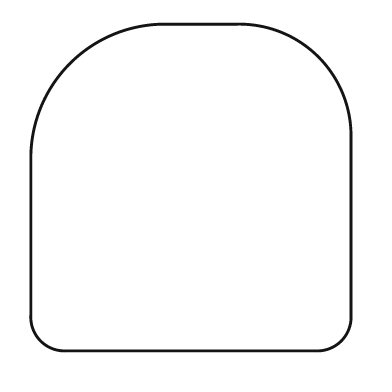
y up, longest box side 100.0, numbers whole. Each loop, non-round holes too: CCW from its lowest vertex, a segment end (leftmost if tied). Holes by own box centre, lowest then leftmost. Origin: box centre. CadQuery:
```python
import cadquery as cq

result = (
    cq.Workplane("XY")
    .moveTo(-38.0, -50.0)
    .lineTo(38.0, -50.0)
    .threePointArc((46.0, -47.0), (49.0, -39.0))
    .lineTo(49.0, 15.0)
    .threePointArc((39.0, 40.0), (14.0, 50.0))
    .lineTo(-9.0, 50.0)
    .threePointArc((-37.0, 38.0), (-49.0, 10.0))
    .lineTo(-49.0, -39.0)
    .threePointArc((-46.0, -47.0), (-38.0, -50.0))
    .close()
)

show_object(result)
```